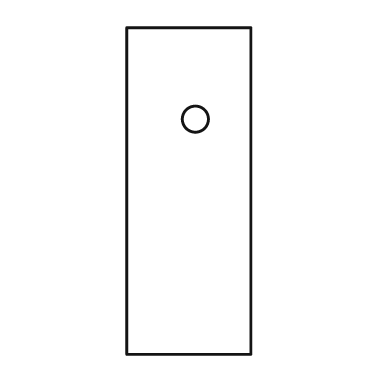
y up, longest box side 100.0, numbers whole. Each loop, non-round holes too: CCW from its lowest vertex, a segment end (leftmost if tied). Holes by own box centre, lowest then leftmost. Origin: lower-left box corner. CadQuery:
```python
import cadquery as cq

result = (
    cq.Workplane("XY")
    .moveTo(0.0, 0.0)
    .lineTo(38.0, 0.0)
    .lineTo(38.0, 100.0)
    .lineTo(0.0, 100.0)
    .close()
    .moveTo(21.0, 72.0)
    .circle(4.0)
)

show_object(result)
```